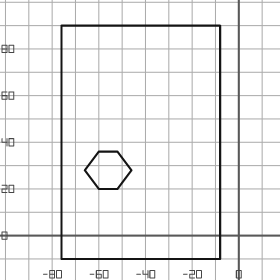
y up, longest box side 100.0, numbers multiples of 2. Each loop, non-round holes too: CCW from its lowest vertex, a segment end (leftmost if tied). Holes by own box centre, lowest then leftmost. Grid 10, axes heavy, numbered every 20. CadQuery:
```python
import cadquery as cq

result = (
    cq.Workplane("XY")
    .moveTo(-76.0, -10.0)
    .lineTo(-8.0, -10.0)
    .lineTo(-8.0, 90.0)
    .lineTo(-76.0, 90.0)
    .close()
    .moveTo(-60.0, 20.0)
    .lineTo(-52.0, 20.0)
    .lineTo(-46.0, 28.0)
    .lineTo(-52.0, 36.0)
    .lineTo(-60.0, 36.0)
    .lineTo(-66.0, 28.0)
    .close()
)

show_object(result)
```